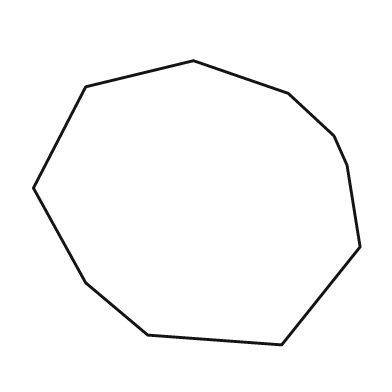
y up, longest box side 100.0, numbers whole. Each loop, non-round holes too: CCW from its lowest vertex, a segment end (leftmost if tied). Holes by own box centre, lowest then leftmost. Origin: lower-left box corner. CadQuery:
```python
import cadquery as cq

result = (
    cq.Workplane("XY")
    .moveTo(76.0, 0.0)
    .lineTo(100.0, 30.0)
    .lineTo(96.0, 55.0)
    .lineTo(92.0, 64.0)
    .lineTo(78.0, 77.0)
    .lineTo(49.0, 87.0)
    .lineTo(16.0, 79.0)
    .lineTo(0.0, 48.0)
    .lineTo(16.0, 19.0)
    .lineTo(35.0, 3.0)
    .close()
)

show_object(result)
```